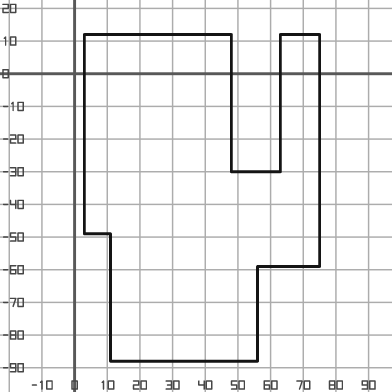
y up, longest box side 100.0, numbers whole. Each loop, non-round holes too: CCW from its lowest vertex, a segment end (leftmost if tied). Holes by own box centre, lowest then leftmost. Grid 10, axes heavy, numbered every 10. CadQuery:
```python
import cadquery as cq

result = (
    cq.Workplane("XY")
    .moveTo(11.0, -88.0)
    .lineTo(56.0, -88.0)
    .lineTo(56.0, -59.0)
    .lineTo(75.0, -59.0)
    .lineTo(75.0, 12.0)
    .lineTo(63.0, 12.0)
    .lineTo(63.0, -30.0)
    .lineTo(48.0, -30.0)
    .lineTo(48.0, 12.0)
    .lineTo(3.0, 12.0)
    .lineTo(3.0, -49.0)
    .lineTo(11.0, -49.0)
    .close()
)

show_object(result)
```